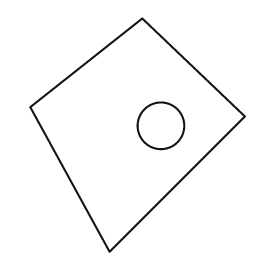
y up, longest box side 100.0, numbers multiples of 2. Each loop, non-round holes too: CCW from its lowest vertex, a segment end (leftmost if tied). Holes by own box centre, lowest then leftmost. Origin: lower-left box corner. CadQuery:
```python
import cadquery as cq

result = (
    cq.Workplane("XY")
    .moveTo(34.0, 0.0)
    .lineTo(92.0, 58.0)
    .lineTo(48.0, 100.0)
    .lineTo(0.0, 62.0)
    .close()
    .moveTo(56.0, 54.0)
    .circle(10.0)
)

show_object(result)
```